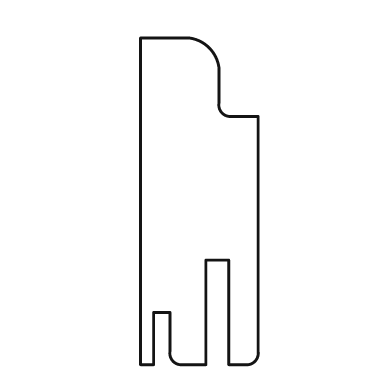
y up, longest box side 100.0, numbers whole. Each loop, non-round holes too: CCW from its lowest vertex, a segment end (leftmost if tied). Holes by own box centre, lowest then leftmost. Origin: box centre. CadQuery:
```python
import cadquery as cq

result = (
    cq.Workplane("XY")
    .moveTo(-18.0, -50.0)
    .lineTo(-14.0, -50.0)
    .lineTo(-14.0, -34.0)
    .lineTo(-9.0, -34.0)
    .lineTo(-9.0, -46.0)
    .threePointArc((-8.0, -49.0), (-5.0, -50.0))
    .lineTo(2.0, -50.0)
    .lineTo(2.0, -18.0)
    .lineTo(9.0, -18.0)
    .lineTo(9.0, -50.0)
    .lineTo(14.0, -50.0)
    .threePointArc((17.0, -49.0), (18.0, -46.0))
    .lineTo(18.0, 26.0)
    .lineTo(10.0, 26.0)
    .threePointArc((7.0, 27.0), (6.0, 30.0))
    .lineTo(6.0, 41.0)
    .threePointArc((3.0, 47.0), (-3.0, 50.0))
    .lineTo(-18.0, 50.0)
    .close()
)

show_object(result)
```